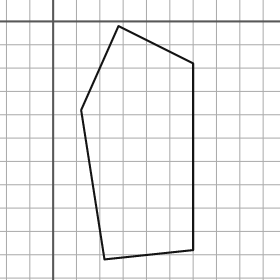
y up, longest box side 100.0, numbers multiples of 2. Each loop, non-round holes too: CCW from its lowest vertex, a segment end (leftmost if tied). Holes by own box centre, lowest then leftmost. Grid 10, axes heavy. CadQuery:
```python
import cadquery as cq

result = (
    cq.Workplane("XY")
    .moveTo(22.0, -102.0)
    .lineTo(60.0, -98.0)
    .lineTo(60.0, -18.0)
    .lineTo(28.0, -2.0)
    .lineTo(12.0, -38.0)
    .close()
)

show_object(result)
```